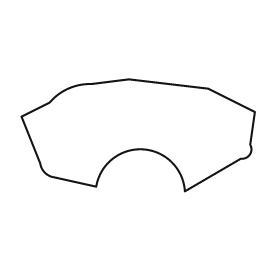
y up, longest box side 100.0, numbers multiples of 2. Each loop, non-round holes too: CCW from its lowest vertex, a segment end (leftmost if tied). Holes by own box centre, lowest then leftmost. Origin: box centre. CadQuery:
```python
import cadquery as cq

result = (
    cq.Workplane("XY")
    .moveTo(20.0, -24.0)
    .lineTo(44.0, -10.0)
    .threePointArc((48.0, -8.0), (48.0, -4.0))
    .lineTo(50.0, 10.0)
    .lineTo(30.0, 20.0)
    .lineTo(-4.0, 24.0)
    .lineTo(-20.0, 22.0)
    .threePointArc((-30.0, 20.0), (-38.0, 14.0))
    .lineTo(-50.0, 8.0)
    .lineTo(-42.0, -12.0)
    .threePointArc((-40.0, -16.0), (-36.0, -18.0))
    .lineTo(-18.0, -22.0)
    .threePointArc((2.0, -6.0), (20.0, -24.0))
    .close()
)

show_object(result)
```